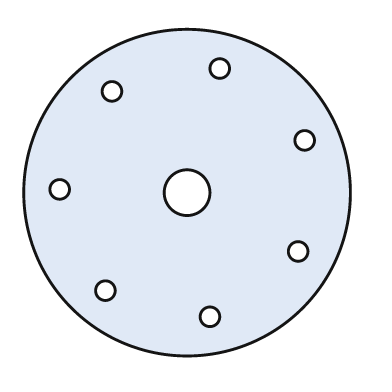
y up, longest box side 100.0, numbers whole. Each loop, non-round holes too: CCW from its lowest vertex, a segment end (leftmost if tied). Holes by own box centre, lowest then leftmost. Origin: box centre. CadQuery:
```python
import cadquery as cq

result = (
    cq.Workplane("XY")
    .moveTo(0.0, 0.0)
    .circle(50.0)
    .moveTo(7.0, -38.0)
    .circle(3.0)
    .moveTo(-25.0, -30.0)
    .circle(3.0)
    .moveTo(34.0, -18.0)
    .circle(3.0)
    .moveTo(0.0, 0.0)
    .circle(7.0)
    .moveTo(-39.0, 1.0)
    .circle(3.0)
    .moveTo(36.0, 16.0)
    .circle(3.0)
    .moveTo(-23.0, 31.0)
    .circle(3.0)
    .moveTo(10.0, 38.0)
    .circle(3.0)
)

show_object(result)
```